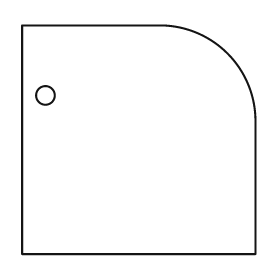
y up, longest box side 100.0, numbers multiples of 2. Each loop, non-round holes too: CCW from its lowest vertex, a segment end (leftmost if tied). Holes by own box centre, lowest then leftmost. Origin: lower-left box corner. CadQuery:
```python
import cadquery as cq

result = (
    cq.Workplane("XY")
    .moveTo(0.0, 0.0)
    .lineTo(100.0, 0.0)
    .lineTo(100.0, 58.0)
    .threePointArc((88.0, 86.0), (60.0, 98.0))
    .lineTo(0.0, 98.0)
    .close()
    .moveTo(10.0, 68.0)
    .circle(4.0)
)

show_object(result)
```